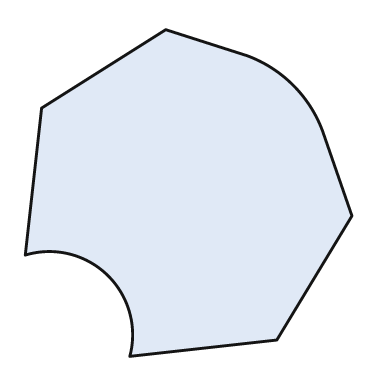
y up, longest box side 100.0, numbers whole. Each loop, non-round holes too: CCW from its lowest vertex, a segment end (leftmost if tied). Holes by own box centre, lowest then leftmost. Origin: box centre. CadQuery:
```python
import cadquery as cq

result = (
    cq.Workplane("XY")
    .moveTo(-18.0, -50.0)
    .lineTo(27.0, -45.0)
    .lineTo(50.0, -7.0)
    .lineTo(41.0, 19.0)
    .threePointArc((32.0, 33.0), (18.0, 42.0))
    .lineTo(-7.0, 50.0)
    .lineTo(-45.0, 26.0)
    .lineTo(-50.0, -19.0)
    .threePointArc((-25.0, -25.0), (-18.0, -50.0))
    .close()
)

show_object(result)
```